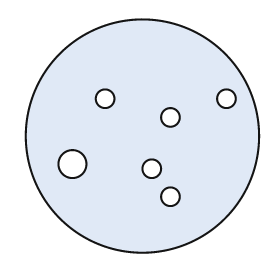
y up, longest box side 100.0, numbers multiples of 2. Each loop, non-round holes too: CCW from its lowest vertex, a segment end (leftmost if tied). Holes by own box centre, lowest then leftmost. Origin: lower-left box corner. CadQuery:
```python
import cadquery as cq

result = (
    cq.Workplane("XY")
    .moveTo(50.0, 50.0)
    .circle(50.0)
    .moveTo(62.0, 24.0)
    .circle(4.0)
    .moveTo(54.0, 36.0)
    .circle(4.0)
    .moveTo(20.0, 38.0)
    .circle(6.0)
    .moveTo(62.0, 58.0)
    .circle(4.0)
    .moveTo(34.0, 66.0)
    .circle(4.0)
    .moveTo(86.0, 66.0)
    .circle(4.0)
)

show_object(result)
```